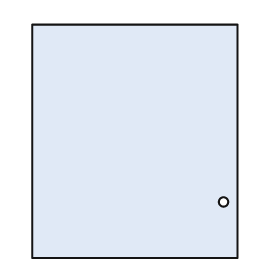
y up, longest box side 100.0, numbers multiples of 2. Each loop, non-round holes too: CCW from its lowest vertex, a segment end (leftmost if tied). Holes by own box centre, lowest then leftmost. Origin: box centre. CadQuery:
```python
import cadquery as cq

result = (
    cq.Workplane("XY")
    .moveTo(-44.0, -50.0)
    .lineTo(44.0, -50.0)
    .lineTo(44.0, 50.0)
    .lineTo(-44.0, 50.0)
    .close()
    .moveTo(38.0, -26.0)
    .circle(2.0)
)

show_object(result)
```